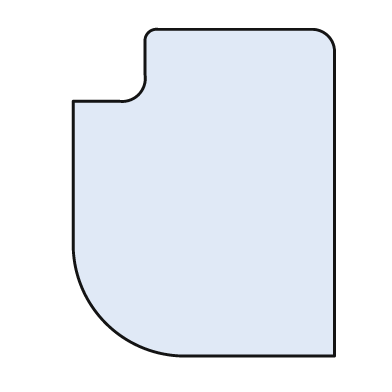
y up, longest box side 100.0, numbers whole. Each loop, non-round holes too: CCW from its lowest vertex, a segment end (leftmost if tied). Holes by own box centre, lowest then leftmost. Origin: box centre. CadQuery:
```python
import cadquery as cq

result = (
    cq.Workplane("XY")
    .moveTo(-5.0, -50.0)
    .lineTo(40.0, -50.0)
    .lineTo(40.0, 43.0)
    .threePointArc((38.0, 48.0), (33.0, 50.0))
    .lineTo(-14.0, 50.0)
    .threePointArc((-17.0, 49.0), (-18.0, 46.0))
    .lineTo(-18.0, 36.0)
    .threePointArc((-20.0, 30.0), (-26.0, 28.0))
    .lineTo(-40.0, 28.0)
    .lineTo(-40.0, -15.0)
    .threePointArc((-30.0, -40.0), (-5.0, -50.0))
    .close()
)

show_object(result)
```